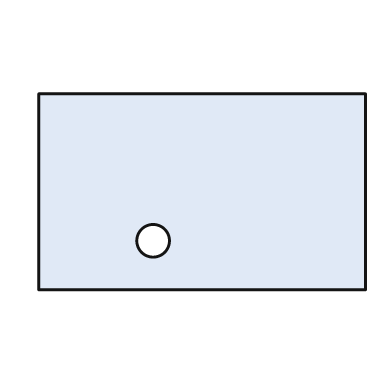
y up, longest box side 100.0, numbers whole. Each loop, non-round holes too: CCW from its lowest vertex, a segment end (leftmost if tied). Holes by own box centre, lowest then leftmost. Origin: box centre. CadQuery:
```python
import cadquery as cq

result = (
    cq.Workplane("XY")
    .moveTo(-50.0, -30.0)
    .lineTo(50.0, -30.0)
    .lineTo(50.0, 30.0)
    .lineTo(-50.0, 30.0)
    .close()
    .moveTo(-15.0, -15.0)
    .circle(5.0)
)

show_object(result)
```